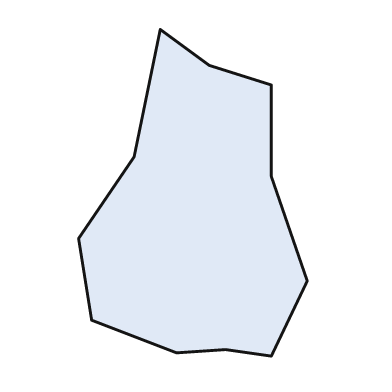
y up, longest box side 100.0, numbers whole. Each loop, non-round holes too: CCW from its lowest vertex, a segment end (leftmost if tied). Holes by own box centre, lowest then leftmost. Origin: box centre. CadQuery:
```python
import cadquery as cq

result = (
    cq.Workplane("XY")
    .moveTo(24.0, -50.0)
    .lineTo(35.0, -27.0)
    .lineTo(24.0, 5.0)
    .lineTo(24.0, 33.0)
    .lineTo(5.0, 39.0)
    .lineTo(-10.0, 50.0)
    .lineTo(-18.0, 11.0)
    .lineTo(-35.0, -14.0)
    .lineTo(-31.0, -39.0)
    .lineTo(-5.0, -49.0)
    .lineTo(10.0, -48.0)
    .close()
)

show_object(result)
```